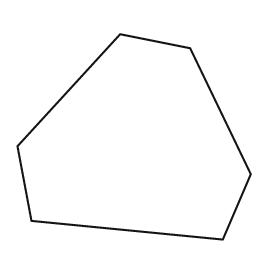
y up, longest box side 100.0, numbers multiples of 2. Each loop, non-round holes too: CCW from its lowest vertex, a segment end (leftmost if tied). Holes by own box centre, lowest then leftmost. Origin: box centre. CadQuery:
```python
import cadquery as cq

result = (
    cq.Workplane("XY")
    .moveTo(38.0, -44.0)
    .lineTo(50.0, -16.0)
    .lineTo(24.0, 38.0)
    .lineTo(-6.0, 44.0)
    .lineTo(-50.0, -4.0)
    .lineTo(-44.0, -36.0)
    .close()
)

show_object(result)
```